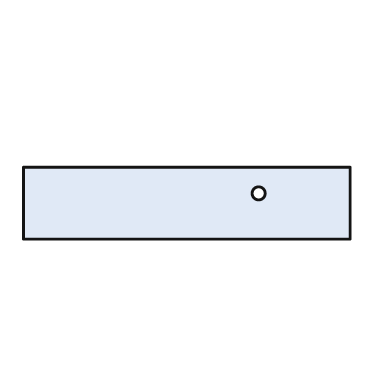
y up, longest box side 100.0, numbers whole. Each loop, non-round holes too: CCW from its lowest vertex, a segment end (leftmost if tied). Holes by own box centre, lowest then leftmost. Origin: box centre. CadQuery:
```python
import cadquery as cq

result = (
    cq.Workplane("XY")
    .moveTo(-50.0, -11.0)
    .lineTo(50.0, -11.0)
    .lineTo(50.0, 11.0)
    .lineTo(-50.0, 11.0)
    .close()
    .moveTo(22.0, 3.0)
    .circle(2.0)
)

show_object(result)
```